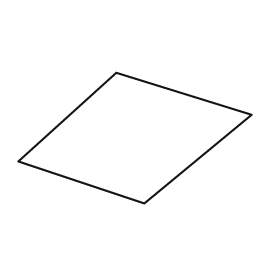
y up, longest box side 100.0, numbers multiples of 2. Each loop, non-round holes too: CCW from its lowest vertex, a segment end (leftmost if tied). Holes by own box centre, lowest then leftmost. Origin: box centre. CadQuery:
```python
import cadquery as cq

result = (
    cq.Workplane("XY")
    .moveTo(4.0, -28.0)
    .lineTo(50.0, 10.0)
    .lineTo(-8.0, 28.0)
    .lineTo(-50.0, -10.0)
    .close()
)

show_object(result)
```